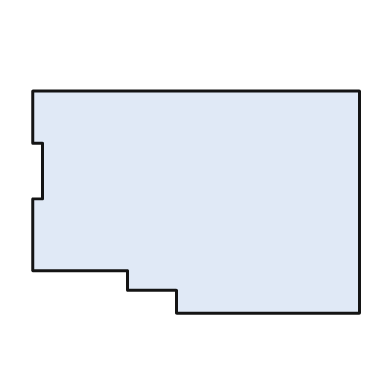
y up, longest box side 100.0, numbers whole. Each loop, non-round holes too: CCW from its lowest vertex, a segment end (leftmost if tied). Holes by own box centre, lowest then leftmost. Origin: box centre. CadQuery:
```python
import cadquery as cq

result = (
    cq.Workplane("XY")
    .moveTo(-6.0, -34.0)
    .lineTo(50.0, -34.0)
    .lineTo(50.0, 34.0)
    .lineTo(-50.0, 34.0)
    .lineTo(-50.0, 18.0)
    .lineTo(-47.0, 18.0)
    .lineTo(-47.0, 1.0)
    .lineTo(-50.0, 1.0)
    .lineTo(-50.0, -21.0)
    .lineTo(-21.0, -21.0)
    .lineTo(-21.0, -27.0)
    .lineTo(-6.0, -27.0)
    .close()
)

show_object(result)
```